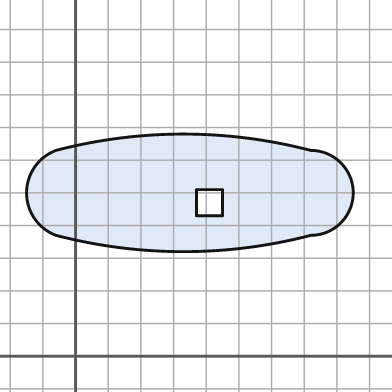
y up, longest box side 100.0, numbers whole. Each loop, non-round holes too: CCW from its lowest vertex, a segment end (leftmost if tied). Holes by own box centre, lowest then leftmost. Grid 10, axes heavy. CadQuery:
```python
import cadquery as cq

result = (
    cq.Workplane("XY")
    .moveTo(-6.0, 37.0)
    .threePointArc((33.0, 32.0), (72.0, 37.0))
    .threePointArc((85.0, 50.0), (72.0, 63.0))
    .threePointArc((33.0, 68.0), (-6.0, 63.0))
    .threePointArc((-15.0, 50.0), (-6.0, 37.0))
    .close()
    .moveTo(37.0, 43.0)
    .lineTo(45.0, 43.0)
    .lineTo(45.0, 51.0)
    .lineTo(37.0, 51.0)
    .close()
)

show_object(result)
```